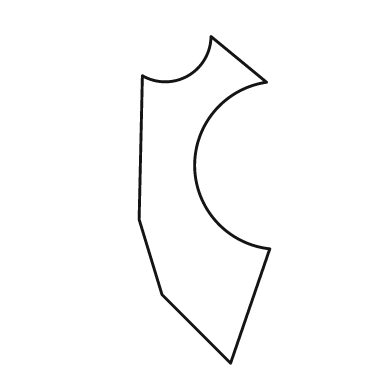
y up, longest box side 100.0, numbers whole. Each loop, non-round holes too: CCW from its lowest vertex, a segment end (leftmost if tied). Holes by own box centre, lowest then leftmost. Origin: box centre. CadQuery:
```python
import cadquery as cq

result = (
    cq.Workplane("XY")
    .moveTo(8.0, -50.0)
    .lineTo(20.0, -15.0)
    .threePointArc((-3.0, 10.0), (19.0, 36.0))
    .lineTo(2.0, 50.0)
    .threePointArc((-5.0, 38.0), (-19.0, 38.0))
    .lineTo(-20.0, -6.0)
    .lineTo(-13.0, -29.0)
    .close()
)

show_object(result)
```